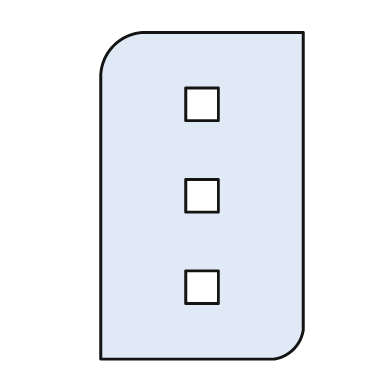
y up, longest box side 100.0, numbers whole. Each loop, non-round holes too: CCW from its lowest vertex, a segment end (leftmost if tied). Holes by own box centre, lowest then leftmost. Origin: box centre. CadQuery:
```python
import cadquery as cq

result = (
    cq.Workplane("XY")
    .moveTo(-31.0, -50.0)
    .lineTo(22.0, -50.0)
    .threePointArc((28.0, -47.0), (31.0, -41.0))
    .lineTo(31.0, 50.0)
    .lineTo(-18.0, 50.0)
    .threePointArc((-27.0, 46.0), (-31.0, 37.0))
    .close()
    .moveTo(-5.0, -33.0)
    .lineTo(5.0, -33.0)
    .lineTo(5.0, -23.0)
    .lineTo(-5.0, -23.0)
    .close()
    .moveTo(-5.0, -5.0)
    .lineTo(5.0, -5.0)
    .lineTo(5.0, 5.0)
    .lineTo(-5.0, 5.0)
    .close()
    .moveTo(-5.0, 23.0)
    .lineTo(5.0, 23.0)
    .lineTo(5.0, 33.0)
    .lineTo(-5.0, 33.0)
    .close()
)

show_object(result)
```